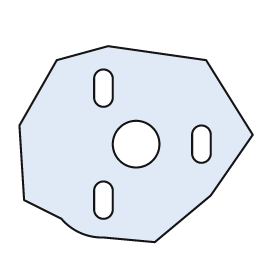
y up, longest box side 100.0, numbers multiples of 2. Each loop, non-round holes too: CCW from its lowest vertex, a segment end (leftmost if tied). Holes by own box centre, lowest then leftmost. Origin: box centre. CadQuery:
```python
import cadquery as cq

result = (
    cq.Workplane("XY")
    .moveTo(8.0, -42.0)
    .lineTo(32.0, -22.0)
    .lineTo(50.0, 4.0)
    .lineTo(30.0, 36.0)
    .lineTo(-12.0, 42.0)
    .lineTo(-34.0, 36.0)
    .lineTo(-50.0, 8.0)
    .lineTo(-48.0, -24.0)
    .lineTo(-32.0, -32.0)
    .threePointArc((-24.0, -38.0), (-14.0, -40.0))
    .close()
    .moveTo(-18.0, -28.0)
    .threePointArc((-14.0, -32.0), (-10.0, -28.0))
    .lineTo(-10.0, -20.0)
    .threePointArc((-14.0, -16.0), (-18.0, -20.0))
    .close()
    .moveTo(0.0, 0.0)
    .circle(10.0)
    .moveTo(24.0, -4.0)
    .threePointArc((28.0, -8.0), (32.0, -4.0))
    .lineTo(32.0, 4.0)
    .threePointArc((28.0, 8.0), (24.0, 4.0))
    .close()
    .moveTo(-18.0, 20.0)
    .threePointArc((-14.0, 16.0), (-10.0, 20.0))
    .lineTo(-10.0, 28.0)
    .threePointArc((-14.0, 32.0), (-18.0, 28.0))
    .close()
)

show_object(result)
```